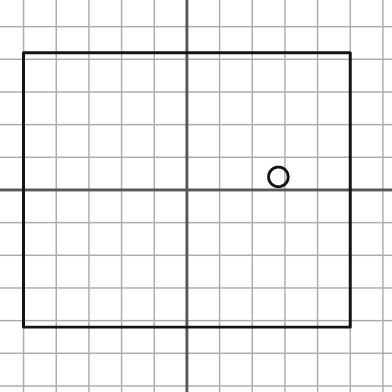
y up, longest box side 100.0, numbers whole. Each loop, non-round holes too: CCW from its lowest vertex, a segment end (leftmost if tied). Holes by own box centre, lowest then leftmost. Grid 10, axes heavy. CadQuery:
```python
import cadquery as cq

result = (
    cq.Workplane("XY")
    .moveTo(-50.0, -42.0)
    .lineTo(50.0, -42.0)
    .lineTo(50.0, 42.0)
    .lineTo(-50.0, 42.0)
    .close()
    .moveTo(28.0, 4.0)
    .circle(3.0)
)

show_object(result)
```